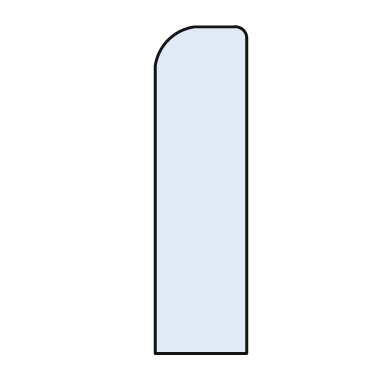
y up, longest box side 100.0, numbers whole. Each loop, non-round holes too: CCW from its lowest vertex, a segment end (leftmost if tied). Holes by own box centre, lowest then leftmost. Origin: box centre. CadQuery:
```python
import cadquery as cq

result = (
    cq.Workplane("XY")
    .moveTo(-14.0, -50.0)
    .lineTo(14.0, -50.0)
    .lineTo(14.0, 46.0)
    .threePointArc((13.0, 49.0), (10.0, 50.0))
    .lineTo(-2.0, 50.0)
    .threePointArc((-10.0, 46.0), (-14.0, 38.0))
    .close()
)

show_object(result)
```